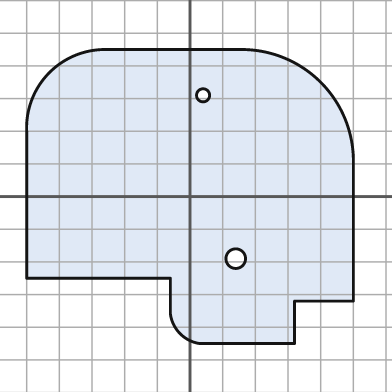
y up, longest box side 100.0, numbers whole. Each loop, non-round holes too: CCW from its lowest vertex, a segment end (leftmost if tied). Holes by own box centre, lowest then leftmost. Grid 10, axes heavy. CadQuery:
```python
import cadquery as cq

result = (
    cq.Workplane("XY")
    .moveTo(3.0, -45.0)
    .lineTo(32.0, -45.0)
    .lineTo(32.0, -32.0)
    .lineTo(50.0, -32.0)
    .lineTo(50.0, 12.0)
    .threePointArc((40.0, 35.0), (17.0, 45.0))
    .lineTo(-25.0, 45.0)
    .threePointArc((-43.0, 38.0), (-50.0, 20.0))
    .lineTo(-50.0, -25.0)
    .lineTo(-6.0, -25.0)
    .lineTo(-6.0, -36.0)
    .threePointArc((-3.0, -42.0), (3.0, -45.0))
    .close()
    .moveTo(14.0, -19.0)
    .circle(3.0)
    .moveTo(4.0, 31.0)
    .circle(2.0)
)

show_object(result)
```